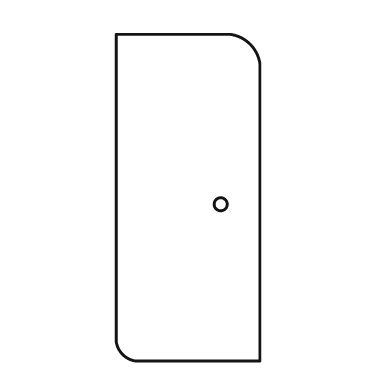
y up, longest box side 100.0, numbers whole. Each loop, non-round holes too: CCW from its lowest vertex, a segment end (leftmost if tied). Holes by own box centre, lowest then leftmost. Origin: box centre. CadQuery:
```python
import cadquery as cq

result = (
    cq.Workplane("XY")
    .moveTo(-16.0, -50.0)
    .lineTo(22.0, -50.0)
    .lineTo(22.0, 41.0)
    .threePointArc((19.0, 47.0), (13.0, 50.0))
    .lineTo(-22.0, 50.0)
    .lineTo(-22.0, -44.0)
    .threePointArc((-20.0, -48.0), (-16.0, -50.0))
    .close()
    .moveTo(10.0, -2.0)
    .circle(2.0)
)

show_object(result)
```